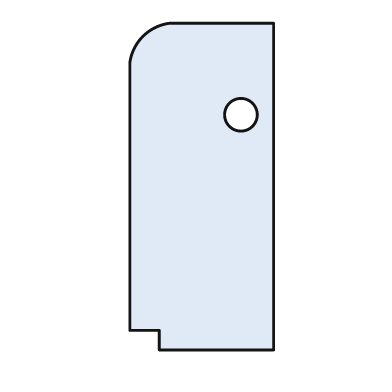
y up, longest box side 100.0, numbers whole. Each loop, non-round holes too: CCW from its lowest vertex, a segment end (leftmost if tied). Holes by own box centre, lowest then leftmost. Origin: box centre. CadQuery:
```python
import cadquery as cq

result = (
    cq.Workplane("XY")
    .moveTo(-13.0, -50.0)
    .lineTo(22.0, -50.0)
    .lineTo(22.0, 50.0)
    .lineTo(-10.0, 50.0)
    .threePointArc((-18.0, 46.0), (-22.0, 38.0))
    .lineTo(-22.0, -44.0)
    .lineTo(-13.0, -44.0)
    .close()
    .moveTo(12.0, 22.0)
    .circle(5.0)
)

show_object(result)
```